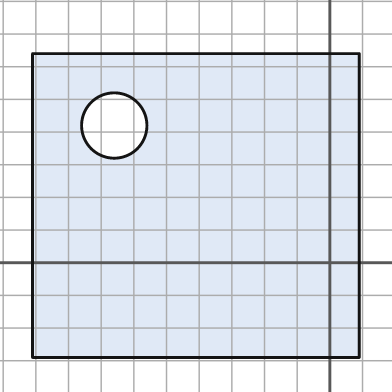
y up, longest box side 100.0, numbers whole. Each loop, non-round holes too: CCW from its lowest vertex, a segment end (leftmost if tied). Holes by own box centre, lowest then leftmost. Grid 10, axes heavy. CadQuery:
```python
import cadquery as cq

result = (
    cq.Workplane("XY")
    .moveTo(-91.0, -29.0)
    .lineTo(9.0, -29.0)
    .lineTo(9.0, 64.0)
    .lineTo(-91.0, 64.0)
    .close()
    .moveTo(-66.0, 42.0)
    .circle(10.0)
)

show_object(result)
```